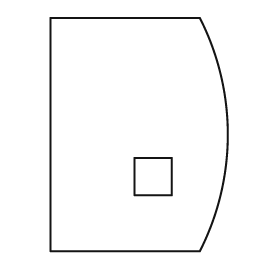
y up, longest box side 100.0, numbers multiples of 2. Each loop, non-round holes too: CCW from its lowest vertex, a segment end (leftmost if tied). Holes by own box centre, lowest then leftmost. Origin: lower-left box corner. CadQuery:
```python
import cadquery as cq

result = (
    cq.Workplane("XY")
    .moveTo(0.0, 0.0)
    .lineTo(64.0, 0.0)
    .threePointArc((76.0, 50.0), (64.0, 100.0))
    .lineTo(0.0, 100.0)
    .close()
    .moveTo(36.0, 24.0)
    .lineTo(52.0, 24.0)
    .lineTo(52.0, 40.0)
    .lineTo(36.0, 40.0)
    .close()
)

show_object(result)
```